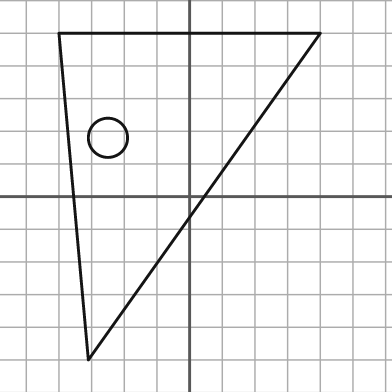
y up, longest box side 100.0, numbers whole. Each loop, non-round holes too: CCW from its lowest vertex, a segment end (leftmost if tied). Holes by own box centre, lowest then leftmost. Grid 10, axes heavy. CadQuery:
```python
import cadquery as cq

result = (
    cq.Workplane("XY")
    .moveTo(-31.0, -50.0)
    .lineTo(40.0, 50.0)
    .lineTo(-40.0, 50.0)
    .close()
    .moveTo(-25.0, 18.0)
    .circle(6.0)
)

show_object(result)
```